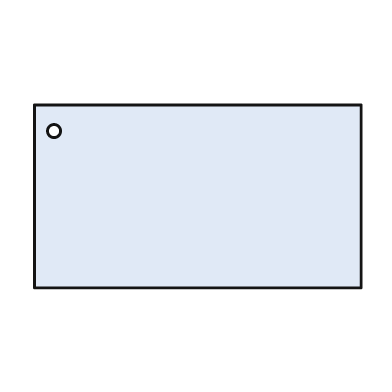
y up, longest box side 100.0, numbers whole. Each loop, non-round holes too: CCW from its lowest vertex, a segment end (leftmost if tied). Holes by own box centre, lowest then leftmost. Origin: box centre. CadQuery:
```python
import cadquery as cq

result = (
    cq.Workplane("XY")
    .moveTo(-50.0, -28.0)
    .lineTo(50.0, -28.0)
    .lineTo(50.0, 28.0)
    .lineTo(-50.0, 28.0)
    .close()
    .moveTo(-44.0, 20.0)
    .circle(2.0)
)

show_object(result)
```